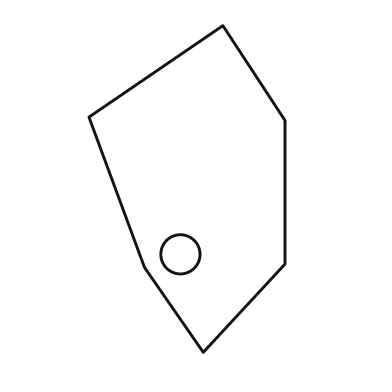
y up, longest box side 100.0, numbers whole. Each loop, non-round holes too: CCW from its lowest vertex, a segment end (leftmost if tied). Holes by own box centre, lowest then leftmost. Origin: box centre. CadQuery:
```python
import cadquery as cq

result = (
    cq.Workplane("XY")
    .moveTo(5.0, -50.0)
    .lineTo(30.0, -23.0)
    .lineTo(30.0, 21.0)
    .lineTo(11.0, 50.0)
    .lineTo(-30.0, 22.0)
    .lineTo(-13.0, -24.0)
    .close()
    .moveTo(-2.0, -20.0)
    .circle(6.0)
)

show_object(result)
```